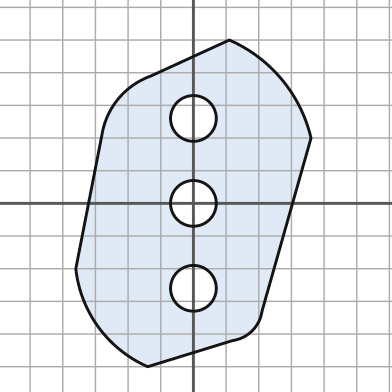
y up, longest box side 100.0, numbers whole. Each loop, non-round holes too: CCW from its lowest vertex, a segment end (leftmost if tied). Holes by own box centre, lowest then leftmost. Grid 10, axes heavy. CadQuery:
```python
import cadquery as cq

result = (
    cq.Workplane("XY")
    .moveTo(-14.0, -50.0)
    .lineTo(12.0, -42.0)
    .threePointArc((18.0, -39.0), (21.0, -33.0))
    .lineTo(36.0, 20.0)
    .threePointArc((27.0, 38.0), (11.0, 50.0))
    .lineTo(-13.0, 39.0)
    .threePointArc((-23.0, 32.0), (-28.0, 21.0))
    .lineTo(-36.0, -20.0)
    .threePointArc((-29.0, -38.0), (-14.0, -50.0))
    .close()
    .moveTo(0.0, -26.0)
    .circle(7.0)
    .moveTo(0.0, 0.0)
    .circle(7.0)
    .moveTo(0.0, 26.0)
    .circle(7.0)
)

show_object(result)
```